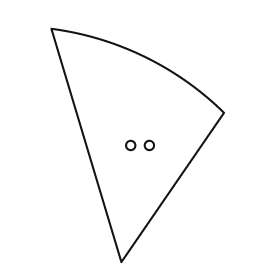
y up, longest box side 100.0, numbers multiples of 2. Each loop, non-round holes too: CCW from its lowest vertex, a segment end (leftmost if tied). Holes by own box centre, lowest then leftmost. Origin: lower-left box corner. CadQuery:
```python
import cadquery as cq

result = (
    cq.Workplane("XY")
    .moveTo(30.0, 0.0)
    .lineTo(74.0, 64.0)
    .threePointArc((40.0, 88.0), (0.0, 100.0))
    .close()
    .moveTo(34.0, 50.0)
    .circle(2.0)
    .moveTo(42.0, 50.0)
    .circle(2.0)
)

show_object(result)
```